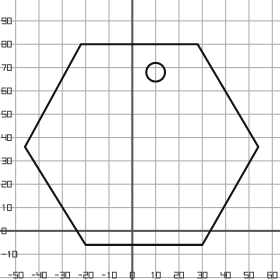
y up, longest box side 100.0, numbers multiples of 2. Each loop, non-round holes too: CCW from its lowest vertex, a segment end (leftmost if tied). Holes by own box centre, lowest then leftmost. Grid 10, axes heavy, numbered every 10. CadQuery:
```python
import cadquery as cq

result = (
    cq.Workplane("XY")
    .moveTo(-20.0, -6.0)
    .lineTo(30.0, -6.0)
    .lineTo(54.0, 36.0)
    .lineTo(28.0, 80.0)
    .lineTo(-22.0, 80.0)
    .lineTo(-46.0, 36.0)
    .close()
    .moveTo(10.0, 68.0)
    .circle(4.0)
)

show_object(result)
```